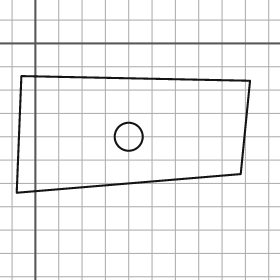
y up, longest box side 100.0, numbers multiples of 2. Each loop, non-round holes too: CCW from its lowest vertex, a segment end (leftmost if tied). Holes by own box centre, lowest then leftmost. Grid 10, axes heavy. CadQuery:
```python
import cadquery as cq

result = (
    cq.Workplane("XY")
    .moveTo(-8.0, -64.0)
    .lineTo(88.0, -56.0)
    .lineTo(92.0, -16.0)
    .lineTo(-6.0, -14.0)
    .close()
    .moveTo(40.0, -40.0)
    .circle(6.0)
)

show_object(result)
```